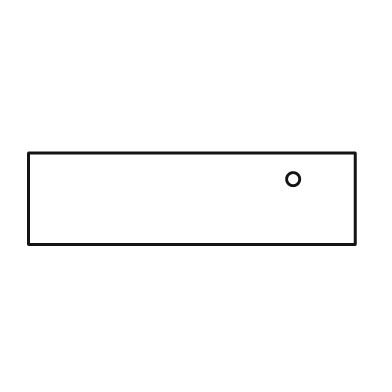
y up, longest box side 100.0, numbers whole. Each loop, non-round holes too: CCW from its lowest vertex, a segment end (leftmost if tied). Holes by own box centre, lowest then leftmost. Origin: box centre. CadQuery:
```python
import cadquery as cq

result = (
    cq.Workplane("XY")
    .moveTo(-50.0, -14.0)
    .lineTo(50.0, -14.0)
    .lineTo(50.0, 14.0)
    .lineTo(-50.0, 14.0)
    .close()
    .moveTo(31.0, 6.0)
    .circle(2.0)
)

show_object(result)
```